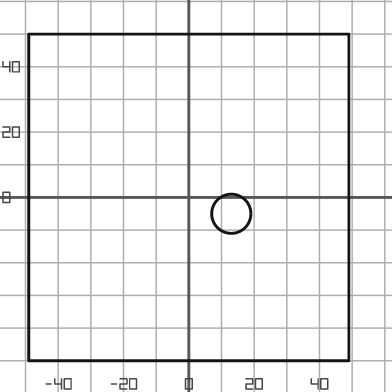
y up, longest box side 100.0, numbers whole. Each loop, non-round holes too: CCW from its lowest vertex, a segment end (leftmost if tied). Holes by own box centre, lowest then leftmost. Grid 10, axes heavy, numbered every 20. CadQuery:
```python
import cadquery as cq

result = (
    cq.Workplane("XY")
    .moveTo(-49.0, -50.0)
    .lineTo(49.0, -50.0)
    .lineTo(49.0, 50.0)
    .lineTo(-49.0, 50.0)
    .close()
    .moveTo(13.0, -5.0)
    .circle(6.0)
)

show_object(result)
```